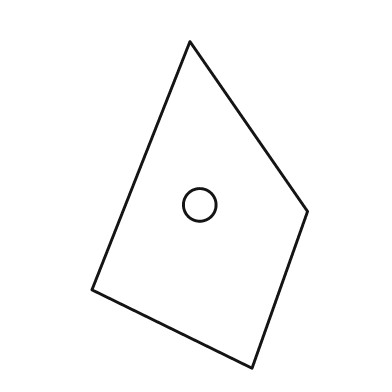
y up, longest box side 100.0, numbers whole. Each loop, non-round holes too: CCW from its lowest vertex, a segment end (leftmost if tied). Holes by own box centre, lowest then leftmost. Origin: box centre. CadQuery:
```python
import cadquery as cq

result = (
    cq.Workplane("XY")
    .moveTo(16.0, -50.0)
    .lineTo(33.0, -2.0)
    .lineTo(-3.0, 50.0)
    .lineTo(-33.0, -26.0)
    .close()
    .moveTo(0.0, 0.0)
    .circle(5.0)
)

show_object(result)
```